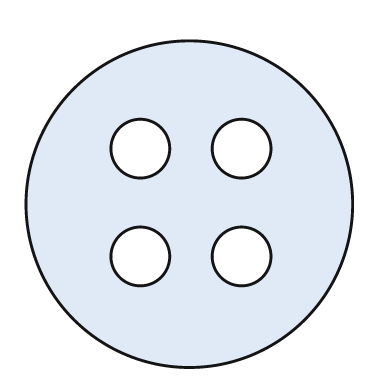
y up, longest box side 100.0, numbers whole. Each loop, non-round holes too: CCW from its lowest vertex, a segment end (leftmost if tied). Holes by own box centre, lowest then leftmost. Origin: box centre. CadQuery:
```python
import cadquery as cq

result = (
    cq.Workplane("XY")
    .moveTo(0.0, 0.0)
    .circle(50.0)
    .moveTo(-15.0, -16.0)
    .circle(9.0)
    .moveTo(16.0, -16.0)
    .circle(9.0)
    .moveTo(-15.0, 17.0)
    .circle(9.0)
    .moveTo(16.0, 17.0)
    .circle(9.0)
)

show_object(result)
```